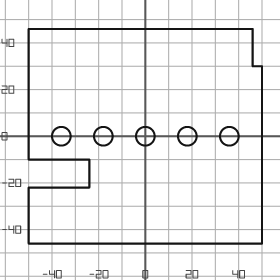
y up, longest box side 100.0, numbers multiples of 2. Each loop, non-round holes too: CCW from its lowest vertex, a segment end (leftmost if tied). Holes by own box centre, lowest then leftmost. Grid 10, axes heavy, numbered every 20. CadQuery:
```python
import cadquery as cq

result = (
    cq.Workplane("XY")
    .moveTo(-50.0, -46.0)
    .lineTo(50.0, -46.0)
    .lineTo(50.0, 30.0)
    .lineTo(46.0, 30.0)
    .lineTo(46.0, 46.0)
    .lineTo(-50.0, 46.0)
    .lineTo(-50.0, -10.0)
    .lineTo(-24.0, -10.0)
    .lineTo(-24.0, -22.0)
    .lineTo(-50.0, -22.0)
    .close()
    .moveTo(-36.0, 0.0)
    .circle(4.0)
    .moveTo(-18.0, 0.0)
    .circle(4.0)
    .moveTo(0.0, 0.0)
    .circle(4.0)
    .moveTo(18.0, 0.0)
    .circle(4.0)
    .moveTo(36.0, 0.0)
    .circle(4.0)
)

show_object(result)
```